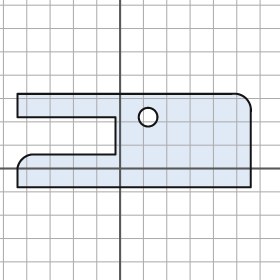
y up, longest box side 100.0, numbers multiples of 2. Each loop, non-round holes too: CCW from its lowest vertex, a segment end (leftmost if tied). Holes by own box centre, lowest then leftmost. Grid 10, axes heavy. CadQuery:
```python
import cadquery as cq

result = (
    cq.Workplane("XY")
    .moveTo(-44.0, -8.0)
    .lineTo(56.0, -8.0)
    .lineTo(56.0, 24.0)
    .threePointArc((54.0, 30.0), (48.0, 32.0))
    .lineTo(-44.0, 32.0)
    .lineTo(-44.0, 22.0)
    .lineTo(-2.0, 22.0)
    .lineTo(-2.0, 6.0)
    .lineTo(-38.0, 6.0)
    .threePointArc((-42.0, 4.0), (-44.0, 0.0))
    .close()
    .moveTo(12.0, 22.0)
    .circle(4.0)
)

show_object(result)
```